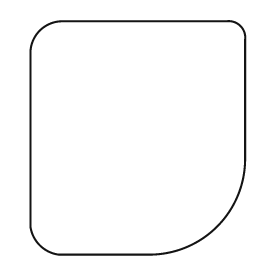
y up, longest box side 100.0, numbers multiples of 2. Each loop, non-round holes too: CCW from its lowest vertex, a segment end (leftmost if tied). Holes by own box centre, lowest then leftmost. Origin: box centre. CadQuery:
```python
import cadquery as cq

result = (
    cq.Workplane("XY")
    .moveTo(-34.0, -50.0)
    .lineTo(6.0, -50.0)
    .threePointArc((34.0, -38.0), (46.0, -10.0))
    .lineTo(46.0, 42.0)
    .threePointArc((44.0, 48.0), (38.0, 50.0))
    .lineTo(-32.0, 50.0)
    .threePointArc((-42.0, 46.0), (-46.0, 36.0))
    .lineTo(-46.0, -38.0)
    .threePointArc((-42.0, -46.0), (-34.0, -50.0))
    .close()
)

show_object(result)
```